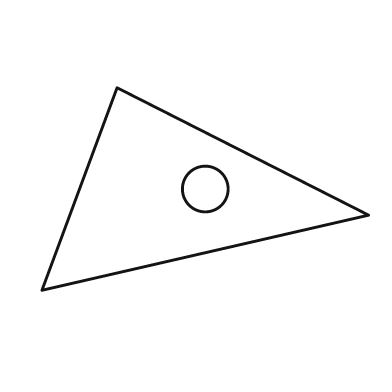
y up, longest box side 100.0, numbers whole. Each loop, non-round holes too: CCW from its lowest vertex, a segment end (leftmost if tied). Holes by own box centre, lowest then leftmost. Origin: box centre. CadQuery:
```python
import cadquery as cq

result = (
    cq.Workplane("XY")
    .moveTo(-50.0, -31.0)
    .lineTo(50.0, -8.0)
    .lineTo(-27.0, 31.0)
    .close()
    .moveTo(0.0, 0.0)
    .circle(7.0)
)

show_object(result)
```